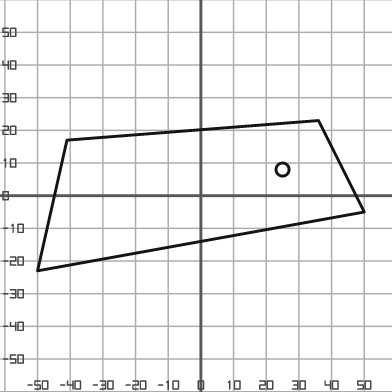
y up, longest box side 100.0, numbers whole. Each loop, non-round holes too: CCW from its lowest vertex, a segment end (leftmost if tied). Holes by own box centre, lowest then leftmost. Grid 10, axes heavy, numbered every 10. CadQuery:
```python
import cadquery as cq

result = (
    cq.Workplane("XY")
    .moveTo(-50.0, -23.0)
    .lineTo(50.0, -5.0)
    .lineTo(36.0, 23.0)
    .lineTo(-41.0, 17.0)
    .close()
    .moveTo(25.0, 8.0)
    .circle(2.0)
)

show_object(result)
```